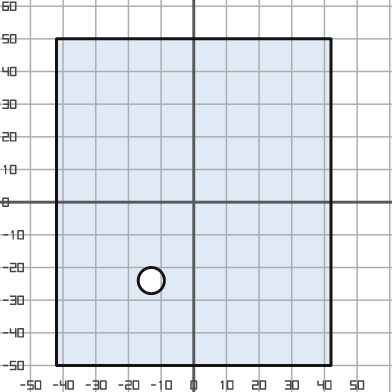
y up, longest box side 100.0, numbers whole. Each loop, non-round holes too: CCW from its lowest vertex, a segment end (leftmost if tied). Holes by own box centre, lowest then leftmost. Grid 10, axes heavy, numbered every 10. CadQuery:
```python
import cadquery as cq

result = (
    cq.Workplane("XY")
    .moveTo(-42.0, -50.0)
    .lineTo(42.0, -50.0)
    .lineTo(42.0, 50.0)
    .lineTo(-42.0, 50.0)
    .close()
    .moveTo(-13.0, -24.0)
    .circle(4.0)
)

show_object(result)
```